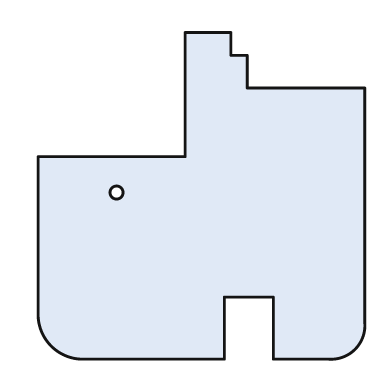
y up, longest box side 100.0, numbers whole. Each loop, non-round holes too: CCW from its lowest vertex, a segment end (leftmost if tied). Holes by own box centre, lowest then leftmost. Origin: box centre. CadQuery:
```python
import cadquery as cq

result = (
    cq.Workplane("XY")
    .moveTo(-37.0, -50.0)
    .lineTo(7.0, -50.0)
    .lineTo(7.0, -31.0)
    .lineTo(22.0, -31.0)
    .lineTo(22.0, -50.0)
    .lineTo(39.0, -50.0)
    .threePointArc((47.0, -47.0), (50.0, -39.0))
    .lineTo(50.0, 33.0)
    .lineTo(14.0, 33.0)
    .lineTo(14.0, 43.0)
    .lineTo(9.0, 43.0)
    .lineTo(9.0, 50.0)
    .lineTo(-5.0, 50.0)
    .lineTo(-5.0, 12.0)
    .lineTo(-50.0, 12.0)
    .lineTo(-50.0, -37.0)
    .threePointArc((-46.0, -46.0), (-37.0, -50.0))
    .close()
    .moveTo(-26.0, 1.0)
    .circle(2.0)
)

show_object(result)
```